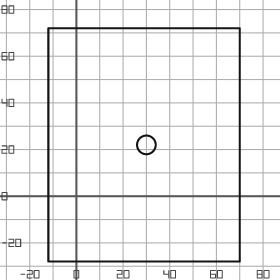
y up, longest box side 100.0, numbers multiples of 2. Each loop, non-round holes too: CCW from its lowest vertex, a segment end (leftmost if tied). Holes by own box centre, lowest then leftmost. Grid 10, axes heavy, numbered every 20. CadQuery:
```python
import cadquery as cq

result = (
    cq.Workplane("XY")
    .moveTo(-12.0, -28.0)
    .lineTo(70.0, -28.0)
    .lineTo(70.0, 72.0)
    .lineTo(-12.0, 72.0)
    .close()
    .moveTo(30.0, 22.0)
    .circle(4.0)
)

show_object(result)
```